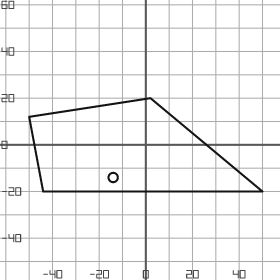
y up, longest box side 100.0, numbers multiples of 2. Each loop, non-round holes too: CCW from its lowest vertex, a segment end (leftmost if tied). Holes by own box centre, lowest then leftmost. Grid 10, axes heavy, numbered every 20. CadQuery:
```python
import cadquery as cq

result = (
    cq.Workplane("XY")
    .moveTo(-44.0, -20.0)
    .lineTo(50.0, -20.0)
    .lineTo(2.0, 20.0)
    .lineTo(-50.0, 12.0)
    .close()
    .moveTo(-14.0, -14.0)
    .circle(2.0)
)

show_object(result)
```